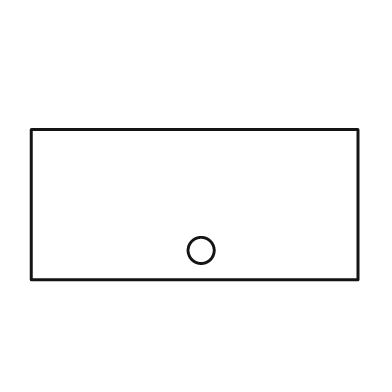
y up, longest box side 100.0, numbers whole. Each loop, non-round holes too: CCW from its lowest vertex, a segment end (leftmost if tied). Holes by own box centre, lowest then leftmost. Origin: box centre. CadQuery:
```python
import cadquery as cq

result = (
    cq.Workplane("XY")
    .moveTo(-50.0, -23.0)
    .lineTo(50.0, -23.0)
    .lineTo(50.0, 23.0)
    .lineTo(-50.0, 23.0)
    .close()
    .moveTo(2.0, -14.0)
    .circle(4.0)
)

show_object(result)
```